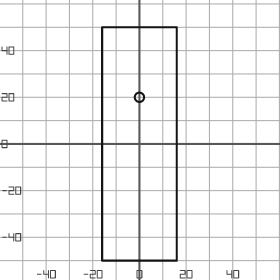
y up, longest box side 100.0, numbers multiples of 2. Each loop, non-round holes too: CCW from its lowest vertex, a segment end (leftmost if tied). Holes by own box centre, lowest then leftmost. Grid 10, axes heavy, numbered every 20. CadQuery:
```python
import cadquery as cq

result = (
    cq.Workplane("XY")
    .moveTo(-16.0, -50.0)
    .lineTo(16.0, -50.0)
    .lineTo(16.0, 50.0)
    .lineTo(-16.0, 50.0)
    .close()
    .moveTo(0.0, 20.0)
    .circle(2.0)
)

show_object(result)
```